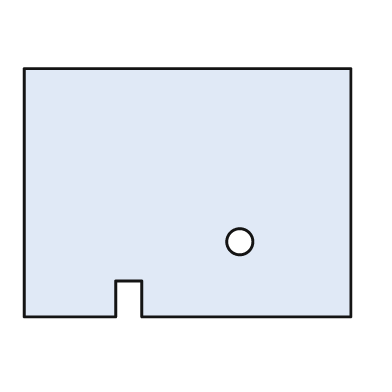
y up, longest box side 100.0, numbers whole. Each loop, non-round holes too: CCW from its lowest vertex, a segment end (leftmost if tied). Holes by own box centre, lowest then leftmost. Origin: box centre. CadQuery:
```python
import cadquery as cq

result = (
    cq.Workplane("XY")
    .moveTo(-50.0, -38.0)
    .lineTo(-22.0, -38.0)
    .lineTo(-22.0, -27.0)
    .lineTo(-14.0, -27.0)
    .lineTo(-14.0, -38.0)
    .lineTo(50.0, -38.0)
    .lineTo(50.0, 38.0)
    .lineTo(-50.0, 38.0)
    .close()
    .moveTo(16.0, -15.0)
    .circle(4.0)
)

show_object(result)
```